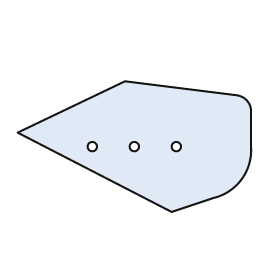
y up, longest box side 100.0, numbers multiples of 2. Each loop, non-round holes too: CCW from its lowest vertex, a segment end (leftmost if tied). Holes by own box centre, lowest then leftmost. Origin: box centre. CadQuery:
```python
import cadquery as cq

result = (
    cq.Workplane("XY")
    .moveTo(16.0, -28.0)
    .lineTo(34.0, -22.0)
    .threePointArc((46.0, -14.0), (50.0, 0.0))
    .lineTo(50.0, 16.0)
    .threePointArc((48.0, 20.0), (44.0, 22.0))
    .lineTo(-4.0, 28.0)
    .lineTo(-50.0, 6.0)
    .close()
    .moveTo(-18.0, 0.0)
    .circle(2.0)
    .moveTo(0.0, 0.0)
    .circle(2.0)
    .moveTo(18.0, 0.0)
    .circle(2.0)
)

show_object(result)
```